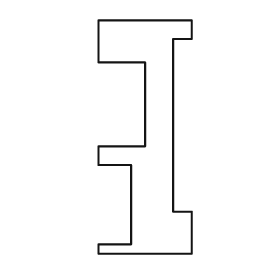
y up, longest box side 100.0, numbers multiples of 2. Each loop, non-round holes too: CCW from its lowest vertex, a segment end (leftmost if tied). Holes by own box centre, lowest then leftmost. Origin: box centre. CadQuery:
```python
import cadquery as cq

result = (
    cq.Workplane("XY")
    .moveTo(-20.0, -50.0)
    .lineTo(20.0, -50.0)
    .lineTo(20.0, -32.0)
    .lineTo(12.0, -32.0)
    .lineTo(12.0, 42.0)
    .lineTo(20.0, 42.0)
    .lineTo(20.0, 50.0)
    .lineTo(-20.0, 50.0)
    .lineTo(-20.0, 32.0)
    .lineTo(0.0, 32.0)
    .lineTo(0.0, -4.0)
    .lineTo(-20.0, -4.0)
    .lineTo(-20.0, -12.0)
    .lineTo(-6.0, -12.0)
    .lineTo(-6.0, -46.0)
    .lineTo(-20.0, -46.0)
    .close()
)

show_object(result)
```